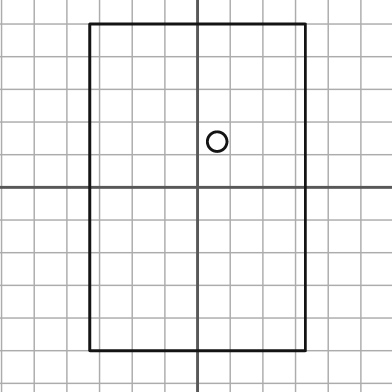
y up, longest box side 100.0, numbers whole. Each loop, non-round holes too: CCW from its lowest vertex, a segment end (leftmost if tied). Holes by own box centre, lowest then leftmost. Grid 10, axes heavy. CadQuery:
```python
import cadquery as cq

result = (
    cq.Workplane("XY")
    .moveTo(-33.0, -50.0)
    .lineTo(33.0, -50.0)
    .lineTo(33.0, 50.0)
    .lineTo(-33.0, 50.0)
    .close()
    .moveTo(6.0, 14.0)
    .circle(3.0)
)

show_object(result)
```